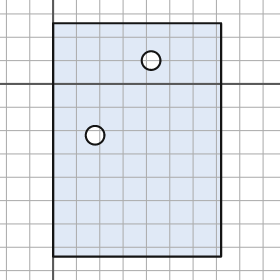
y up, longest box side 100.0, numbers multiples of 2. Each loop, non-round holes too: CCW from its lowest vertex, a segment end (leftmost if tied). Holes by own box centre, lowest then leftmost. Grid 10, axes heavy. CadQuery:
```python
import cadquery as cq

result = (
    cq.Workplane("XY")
    .moveTo(0.0, -74.0)
    .lineTo(72.0, -74.0)
    .lineTo(72.0, 26.0)
    .lineTo(0.0, 26.0)
    .close()
    .moveTo(18.0, -22.0)
    .circle(4.0)
    .moveTo(42.0, 10.0)
    .circle(4.0)
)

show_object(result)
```